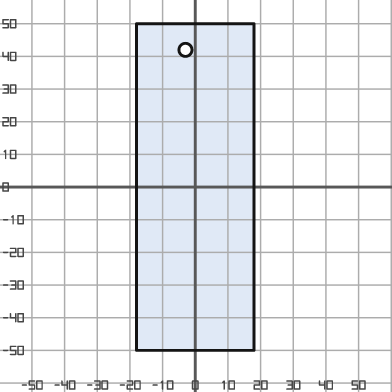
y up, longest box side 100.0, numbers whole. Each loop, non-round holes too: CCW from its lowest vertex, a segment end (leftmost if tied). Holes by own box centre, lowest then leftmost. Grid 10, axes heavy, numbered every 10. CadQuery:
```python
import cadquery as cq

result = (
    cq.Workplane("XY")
    .moveTo(-18.0, -50.0)
    .lineTo(18.0, -50.0)
    .lineTo(18.0, 50.0)
    .lineTo(-18.0, 50.0)
    .close()
    .moveTo(-3.0, 42.0)
    .circle(2.0)
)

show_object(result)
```